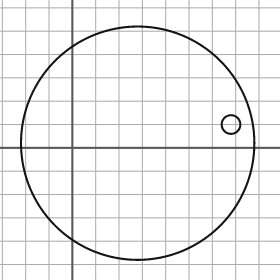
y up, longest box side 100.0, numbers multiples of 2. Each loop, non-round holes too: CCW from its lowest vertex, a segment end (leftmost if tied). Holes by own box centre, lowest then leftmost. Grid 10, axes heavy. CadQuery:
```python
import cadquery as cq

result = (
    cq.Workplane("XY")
    .moveTo(28.0, 2.0)
    .circle(50.0)
    .moveTo(68.0, 10.0)
    .circle(4.0)
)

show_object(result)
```